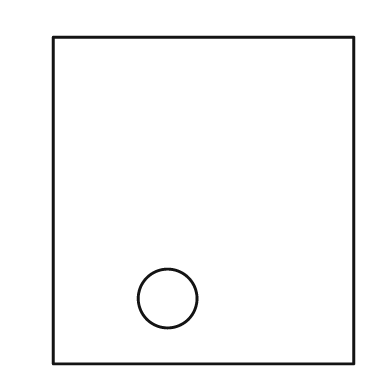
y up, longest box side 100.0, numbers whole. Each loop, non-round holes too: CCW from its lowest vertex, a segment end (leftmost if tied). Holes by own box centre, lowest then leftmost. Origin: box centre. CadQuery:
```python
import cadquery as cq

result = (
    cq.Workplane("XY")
    .moveTo(-46.0, -50.0)
    .lineTo(46.0, -50.0)
    .lineTo(46.0, 50.0)
    .lineTo(-46.0, 50.0)
    .close()
    .moveTo(-11.0, -30.0)
    .circle(9.0)
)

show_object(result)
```